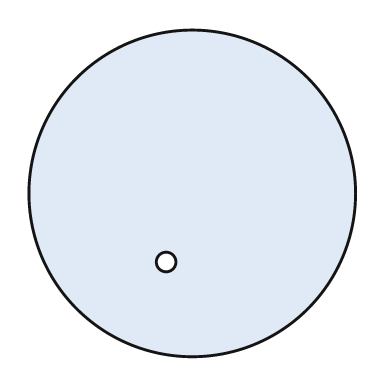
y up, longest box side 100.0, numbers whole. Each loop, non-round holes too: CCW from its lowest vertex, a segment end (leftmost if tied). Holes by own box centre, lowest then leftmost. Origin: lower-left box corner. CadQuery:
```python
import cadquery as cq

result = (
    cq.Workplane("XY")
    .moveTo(50.0, 50.0)
    .circle(50.0)
    .moveTo(42.0, 29.0)
    .circle(3.0)
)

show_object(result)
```